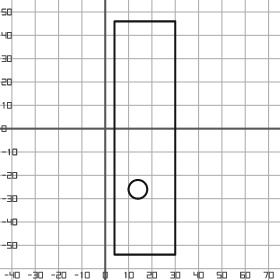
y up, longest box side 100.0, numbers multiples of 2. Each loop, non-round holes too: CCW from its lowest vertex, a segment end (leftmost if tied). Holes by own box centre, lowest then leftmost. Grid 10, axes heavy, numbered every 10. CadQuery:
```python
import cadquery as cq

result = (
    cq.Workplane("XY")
    .moveTo(4.0, -54.0)
    .lineTo(30.0, -54.0)
    .lineTo(30.0, 46.0)
    .lineTo(4.0, 46.0)
    .close()
    .moveTo(14.0, -26.0)
    .circle(4.0)
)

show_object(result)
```